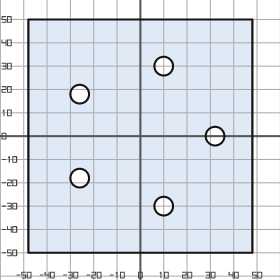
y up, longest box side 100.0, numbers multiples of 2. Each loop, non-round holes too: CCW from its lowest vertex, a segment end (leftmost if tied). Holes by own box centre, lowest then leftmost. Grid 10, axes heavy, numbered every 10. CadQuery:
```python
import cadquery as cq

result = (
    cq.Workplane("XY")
    .moveTo(-48.0, -50.0)
    .lineTo(48.0, -50.0)
    .lineTo(48.0, 50.0)
    .lineTo(-48.0, 50.0)
    .close()
    .moveTo(10.0, -30.0)
    .circle(4.0)
    .moveTo(-26.0, -18.0)
    .circle(4.0)
    .moveTo(32.0, 0.0)
    .circle(4.0)
    .moveTo(-26.0, 18.0)
    .circle(4.0)
    .moveTo(10.0, 30.0)
    .circle(4.0)
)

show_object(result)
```